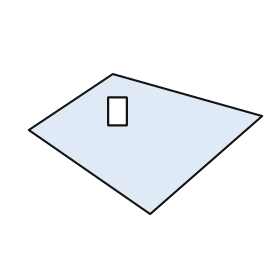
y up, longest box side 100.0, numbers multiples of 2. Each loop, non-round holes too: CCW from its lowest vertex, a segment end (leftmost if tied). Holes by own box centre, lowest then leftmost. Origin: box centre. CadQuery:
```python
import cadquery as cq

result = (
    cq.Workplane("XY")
    .moveTo(2.0, -30.0)
    .lineTo(50.0, 12.0)
    .lineTo(-14.0, 30.0)
    .lineTo(-50.0, 6.0)
    .close()
    .moveTo(-16.0, 8.0)
    .lineTo(-8.0, 8.0)
    .lineTo(-8.0, 20.0)
    .lineTo(-16.0, 20.0)
    .close()
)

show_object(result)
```